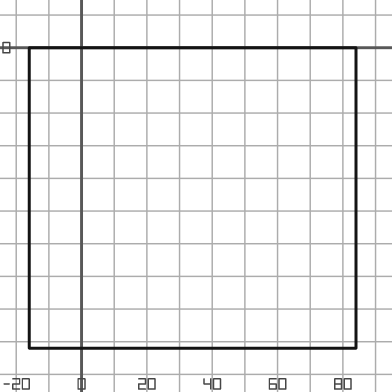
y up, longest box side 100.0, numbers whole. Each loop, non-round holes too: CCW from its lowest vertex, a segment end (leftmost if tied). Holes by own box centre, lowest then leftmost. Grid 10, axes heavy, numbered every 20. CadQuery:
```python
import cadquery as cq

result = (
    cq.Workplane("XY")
    .moveTo(-16.0, -92.0)
    .lineTo(84.0, -92.0)
    .lineTo(84.0, 0.0)
    .lineTo(-16.0, 0.0)
    .close()
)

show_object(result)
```